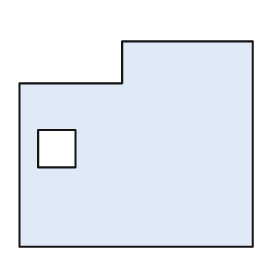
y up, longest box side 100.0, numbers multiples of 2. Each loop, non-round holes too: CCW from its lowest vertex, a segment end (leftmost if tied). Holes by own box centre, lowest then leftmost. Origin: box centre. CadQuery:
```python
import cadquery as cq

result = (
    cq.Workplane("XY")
    .moveTo(-50.0, -44.0)
    .lineTo(50.0, -44.0)
    .lineTo(50.0, 44.0)
    .lineTo(-6.0, 44.0)
    .lineTo(-6.0, 26.0)
    .lineTo(-50.0, 26.0)
    .close()
    .moveTo(-42.0, -10.0)
    .lineTo(-26.0, -10.0)
    .lineTo(-26.0, 6.0)
    .lineTo(-42.0, 6.0)
    .close()
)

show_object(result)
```